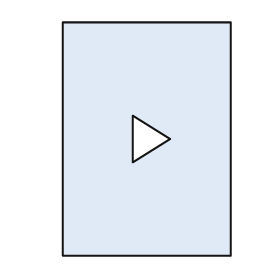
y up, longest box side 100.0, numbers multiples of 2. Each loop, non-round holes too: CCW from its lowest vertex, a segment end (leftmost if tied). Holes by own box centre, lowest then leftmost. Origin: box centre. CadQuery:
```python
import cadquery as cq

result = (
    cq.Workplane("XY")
    .moveTo(-36.0, -50.0)
    .lineTo(36.0, -50.0)
    .lineTo(36.0, 50.0)
    .lineTo(-36.0, 50.0)
    .close()
    .moveTo(-6.0, -10.0)
    .lineTo(10.0, 0.0)
    .lineTo(-6.0, 10.0)
    .close()
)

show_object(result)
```